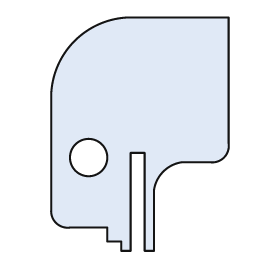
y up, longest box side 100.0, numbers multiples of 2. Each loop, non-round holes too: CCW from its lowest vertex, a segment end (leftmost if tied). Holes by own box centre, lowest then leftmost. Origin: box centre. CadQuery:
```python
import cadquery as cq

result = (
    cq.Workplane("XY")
    .moveTo(-8.0, -50.0)
    .lineTo(-4.0, -50.0)
    .lineTo(-4.0, -8.0)
    .lineTo(2.0, -8.0)
    .lineTo(2.0, -50.0)
    .lineTo(6.0, -50.0)
    .lineTo(6.0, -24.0)
    .threePointArc((10.0, -16.0), (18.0, -12.0))
    .lineTo(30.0, -12.0)
    .threePointArc((36.0, -10.0), (38.0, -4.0))
    .lineTo(38.0, 50.0)
    .lineTo(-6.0, 50.0)
    .threePointArc((-28.0, 40.0), (-38.0, 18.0))
    .lineTo(-38.0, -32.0)
    .threePointArc((-36.0, -38.0), (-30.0, -40.0))
    .lineTo(-14.0, -40.0)
    .lineTo(-14.0, -46.0)
    .lineTo(-8.0, -46.0)
    .close()
    .moveTo(-22.0, -10.0)
    .circle(8.0)
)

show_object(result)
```